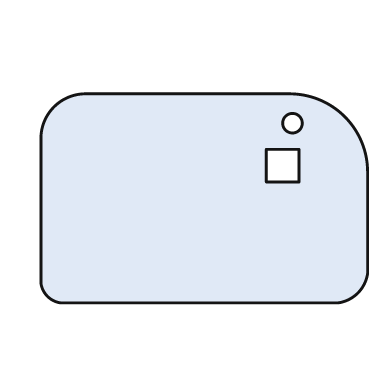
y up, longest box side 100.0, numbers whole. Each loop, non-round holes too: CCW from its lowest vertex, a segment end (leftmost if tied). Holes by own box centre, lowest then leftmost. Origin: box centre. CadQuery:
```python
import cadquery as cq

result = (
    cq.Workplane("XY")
    .moveTo(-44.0, -32.0)
    .lineTo(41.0, -32.0)
    .threePointArc((47.0, -29.0), (50.0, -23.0))
    .lineTo(50.0, 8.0)
    .threePointArc((43.0, 25.0), (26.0, 32.0))
    .lineTo(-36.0, 32.0)
    .threePointArc((-46.0, 28.0), (-50.0, 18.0))
    .lineTo(-50.0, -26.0)
    .threePointArc((-48.0, -30.0), (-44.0, -32.0))
    .close()
    .moveTo(19.0, 5.0)
    .lineTo(29.0, 5.0)
    .lineTo(29.0, 15.0)
    .lineTo(19.0, 15.0)
    .close()
    .moveTo(27.0, 23.0)
    .circle(3.0)
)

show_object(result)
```